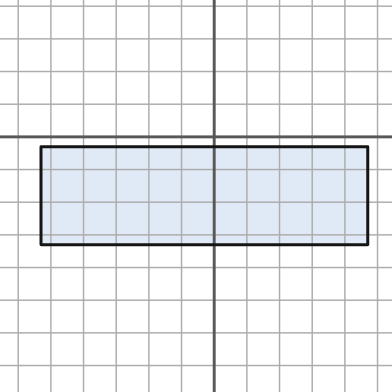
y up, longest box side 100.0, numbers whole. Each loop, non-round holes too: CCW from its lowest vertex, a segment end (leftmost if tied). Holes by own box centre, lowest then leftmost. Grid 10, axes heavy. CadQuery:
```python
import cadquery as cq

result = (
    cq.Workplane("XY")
    .moveTo(-53.0, -33.0)
    .lineTo(47.0, -33.0)
    .lineTo(47.0, -3.0)
    .lineTo(-53.0, -3.0)
    .close()
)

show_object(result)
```